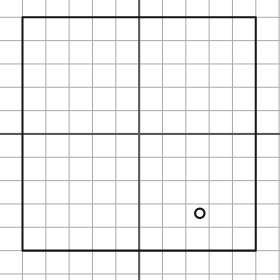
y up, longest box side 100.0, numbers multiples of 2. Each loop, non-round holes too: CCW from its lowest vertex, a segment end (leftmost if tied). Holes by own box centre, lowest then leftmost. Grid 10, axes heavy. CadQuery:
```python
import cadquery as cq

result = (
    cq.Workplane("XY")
    .moveTo(-50.0, -50.0)
    .lineTo(50.0, -50.0)
    .lineTo(50.0, 50.0)
    .lineTo(-50.0, 50.0)
    .close()
    .moveTo(26.0, -34.0)
    .circle(2.0)
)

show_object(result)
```